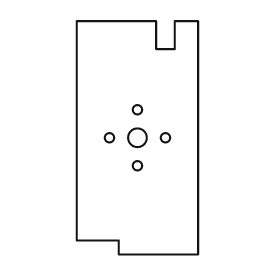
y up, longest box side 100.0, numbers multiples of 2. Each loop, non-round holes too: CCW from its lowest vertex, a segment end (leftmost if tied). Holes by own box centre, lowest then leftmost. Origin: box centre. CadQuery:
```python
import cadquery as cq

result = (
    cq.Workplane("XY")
    .moveTo(-8.0, -50.0)
    .lineTo(26.0, -50.0)
    .lineTo(26.0, 50.0)
    .lineTo(16.0, 50.0)
    .lineTo(16.0, 38.0)
    .lineTo(8.0, 38.0)
    .lineTo(8.0, 50.0)
    .lineTo(-26.0, 50.0)
    .lineTo(-26.0, -44.0)
    .lineTo(-8.0, -44.0)
    .close()
    .moveTo(0.0, -12.0)
    .circle(2.0)
    .moveTo(-12.0, 0.0)
    .circle(2.0)
    .moveTo(0.0, 0.0)
    .circle(4.0)
    .moveTo(12.0, 0.0)
    .circle(2.0)
    .moveTo(0.0, 12.0)
    .circle(2.0)
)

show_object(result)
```